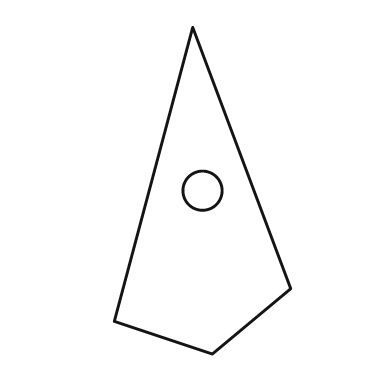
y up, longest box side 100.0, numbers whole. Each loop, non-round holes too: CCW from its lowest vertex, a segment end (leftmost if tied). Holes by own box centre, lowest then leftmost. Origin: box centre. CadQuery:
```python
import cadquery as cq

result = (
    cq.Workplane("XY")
    .moveTo(3.0, -50.0)
    .lineTo(27.0, -30.0)
    .lineTo(-3.0, 50.0)
    .lineTo(-27.0, -40.0)
    .close()
    .moveTo(0.0, 0.0)
    .circle(6.0)
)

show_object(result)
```